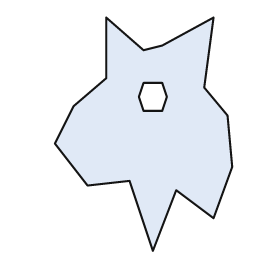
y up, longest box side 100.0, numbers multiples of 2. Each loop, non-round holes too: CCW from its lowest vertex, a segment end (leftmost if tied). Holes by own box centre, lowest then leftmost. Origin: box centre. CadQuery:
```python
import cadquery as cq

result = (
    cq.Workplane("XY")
    .moveTo(4.0, -50.0)
    .lineTo(14.0, -24.0)
    .lineTo(30.0, -36.0)
    .lineTo(38.0, -14.0)
    .lineTo(36.0, 8.0)
    .lineTo(26.0, 20.0)
    .lineTo(30.0, 50.0)
    .lineTo(8.0, 38.0)
    .lineTo(0.0, 36.0)
    .lineTo(-16.0, 50.0)
    .lineTo(-16.0, 24.0)
    .lineTo(-30.0, 12.0)
    .lineTo(-38.0, -4.0)
    .lineTo(-24.0, -22.0)
    .lineTo(-6.0, -20.0)
    .close()
    .moveTo(0.0, 10.0)
    .lineTo(8.0, 10.0)
    .lineTo(10.0, 16.0)
    .lineTo(8.0, 22.0)
    .lineTo(0.0, 22.0)
    .lineTo(-2.0, 16.0)
    .close()
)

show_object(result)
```